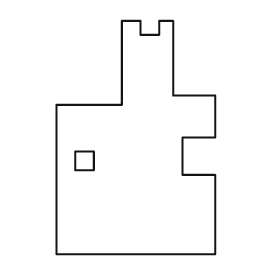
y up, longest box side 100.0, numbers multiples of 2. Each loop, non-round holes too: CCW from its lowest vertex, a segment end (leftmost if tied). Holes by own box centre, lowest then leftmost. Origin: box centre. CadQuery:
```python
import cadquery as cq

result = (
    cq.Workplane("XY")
    .moveTo(-34.0, -50.0)
    .lineTo(34.0, -50.0)
    .lineTo(34.0, -16.0)
    .lineTo(20.0, -16.0)
    .lineTo(20.0, 0.0)
    .lineTo(34.0, 0.0)
    .lineTo(34.0, 18.0)
    .lineTo(16.0, 18.0)
    .lineTo(16.0, 50.0)
    .lineTo(10.0, 50.0)
    .lineTo(10.0, 44.0)
    .lineTo(2.0, 44.0)
    .lineTo(2.0, 50.0)
    .lineTo(-6.0, 50.0)
    .lineTo(-6.0, 14.0)
    .lineTo(-34.0, 14.0)
    .close()
    .moveTo(-26.0, -14.0)
    .lineTo(-18.0, -14.0)
    .lineTo(-18.0, -6.0)
    .lineTo(-26.0, -6.0)
    .close()
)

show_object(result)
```